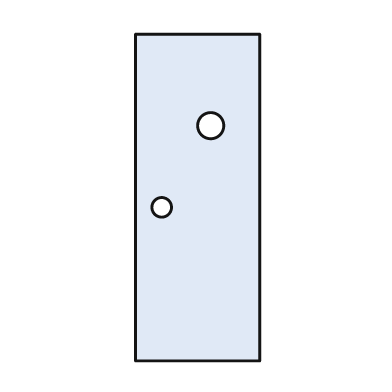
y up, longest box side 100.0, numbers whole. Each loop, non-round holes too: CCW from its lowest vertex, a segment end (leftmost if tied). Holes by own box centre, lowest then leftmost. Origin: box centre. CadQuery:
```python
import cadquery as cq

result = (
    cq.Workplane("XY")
    .moveTo(-19.0, -50.0)
    .lineTo(19.0, -50.0)
    .lineTo(19.0, 50.0)
    .lineTo(-19.0, 50.0)
    .close()
    .moveTo(-11.0, -3.0)
    .circle(3.0)
    .moveTo(4.0, 22.0)
    .circle(4.0)
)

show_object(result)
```